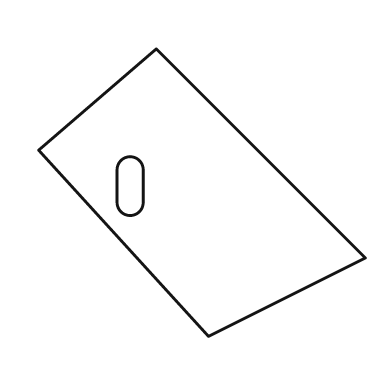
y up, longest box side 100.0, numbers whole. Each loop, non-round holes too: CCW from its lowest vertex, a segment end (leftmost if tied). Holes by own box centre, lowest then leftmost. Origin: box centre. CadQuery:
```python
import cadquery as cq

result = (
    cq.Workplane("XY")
    .moveTo(2.0, -44.0)
    .lineTo(50.0, -20.0)
    .lineTo(-14.0, 44.0)
    .lineTo(-50.0, 13.0)
    .close()
    .moveTo(-26.0, -3.0)
    .threePointArc((-22.0, -7.0), (-18.0, -3.0))
    .lineTo(-18.0, 7.0)
    .threePointArc((-22.0, 11.0), (-26.0, 7.0))
    .close()
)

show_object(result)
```